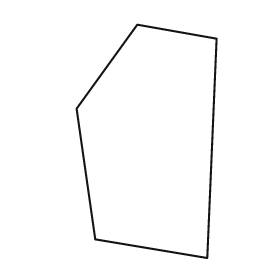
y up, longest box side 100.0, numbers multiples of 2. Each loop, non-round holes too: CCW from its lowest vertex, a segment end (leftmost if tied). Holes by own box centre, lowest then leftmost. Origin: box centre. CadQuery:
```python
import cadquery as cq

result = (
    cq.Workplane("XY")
    .moveTo(26.0, -50.0)
    .lineTo(30.0, 44.0)
    .lineTo(-4.0, 50.0)
    .lineTo(-30.0, 14.0)
    .lineTo(-22.0, -42.0)
    .close()
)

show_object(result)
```